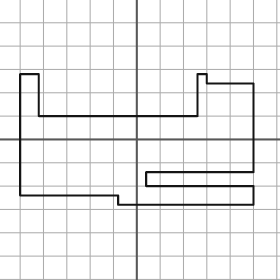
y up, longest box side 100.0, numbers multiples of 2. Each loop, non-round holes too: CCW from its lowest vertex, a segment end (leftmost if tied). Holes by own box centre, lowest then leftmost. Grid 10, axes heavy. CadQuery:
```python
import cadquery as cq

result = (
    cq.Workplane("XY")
    .moveTo(-8.0, -28.0)
    .lineTo(50.0, -28.0)
    .lineTo(50.0, -20.0)
    .lineTo(4.0, -20.0)
    .lineTo(4.0, -14.0)
    .lineTo(50.0, -14.0)
    .lineTo(50.0, 24.0)
    .lineTo(30.0, 24.0)
    .lineTo(30.0, 28.0)
    .lineTo(26.0, 28.0)
    .lineTo(26.0, 10.0)
    .lineTo(-42.0, 10.0)
    .lineTo(-42.0, 28.0)
    .lineTo(-50.0, 28.0)
    .lineTo(-50.0, -24.0)
    .lineTo(-8.0, -24.0)
    .close()
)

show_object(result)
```